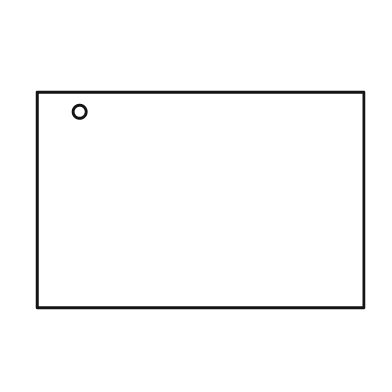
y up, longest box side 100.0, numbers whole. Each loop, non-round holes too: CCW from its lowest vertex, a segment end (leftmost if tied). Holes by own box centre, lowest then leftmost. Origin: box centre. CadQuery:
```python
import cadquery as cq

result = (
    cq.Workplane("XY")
    .moveTo(-50.0, -33.0)
    .lineTo(50.0, -33.0)
    .lineTo(50.0, 33.0)
    .lineTo(-50.0, 33.0)
    .close()
    .moveTo(-37.0, 27.0)
    .circle(2.0)
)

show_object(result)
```